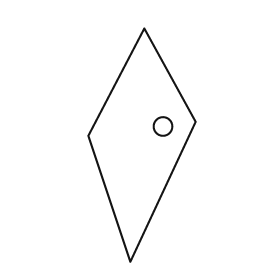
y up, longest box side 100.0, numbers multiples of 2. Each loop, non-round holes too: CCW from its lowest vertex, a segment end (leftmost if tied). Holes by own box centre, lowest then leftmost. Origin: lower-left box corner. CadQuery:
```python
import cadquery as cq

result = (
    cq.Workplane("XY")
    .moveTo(18.0, 0.0)
    .lineTo(46.0, 60.0)
    .lineTo(24.0, 100.0)
    .lineTo(0.0, 54.0)
    .close()
    .moveTo(32.0, 58.0)
    .circle(4.0)
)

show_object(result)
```